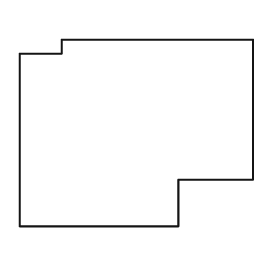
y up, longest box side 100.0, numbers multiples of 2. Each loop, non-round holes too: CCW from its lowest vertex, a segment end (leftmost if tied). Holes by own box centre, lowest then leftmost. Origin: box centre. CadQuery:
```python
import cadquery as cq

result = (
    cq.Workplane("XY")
    .moveTo(-50.0, -40.0)
    .lineTo(18.0, -40.0)
    .lineTo(18.0, -20.0)
    .lineTo(50.0, -20.0)
    .lineTo(50.0, 40.0)
    .lineTo(-32.0, 40.0)
    .lineTo(-32.0, 34.0)
    .lineTo(-50.0, 34.0)
    .close()
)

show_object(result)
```